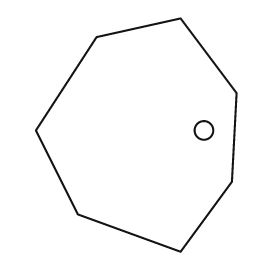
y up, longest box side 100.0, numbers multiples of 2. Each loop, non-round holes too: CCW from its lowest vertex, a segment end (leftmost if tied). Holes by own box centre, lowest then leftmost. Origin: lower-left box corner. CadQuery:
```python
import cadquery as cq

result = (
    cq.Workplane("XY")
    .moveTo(62.0, 0.0)
    .lineTo(84.0, 30.0)
    .lineTo(86.0, 68.0)
    .lineTo(62.0, 100.0)
    .lineTo(26.0, 92.0)
    .lineTo(0.0, 52.0)
    .lineTo(18.0, 16.0)
    .close()
    .moveTo(72.0, 52.0)
    .circle(4.0)
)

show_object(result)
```